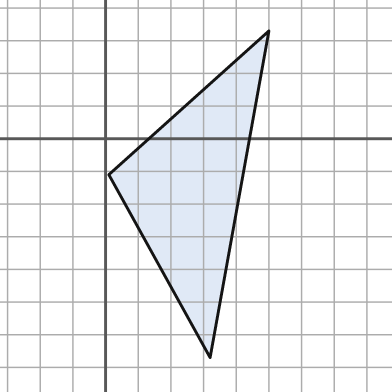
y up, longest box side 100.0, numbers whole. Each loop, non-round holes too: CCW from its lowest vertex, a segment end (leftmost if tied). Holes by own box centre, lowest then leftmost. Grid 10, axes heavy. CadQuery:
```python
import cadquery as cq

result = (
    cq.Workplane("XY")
    .moveTo(32.0, -67.0)
    .lineTo(50.0, 33.0)
    .lineTo(1.0, -11.0)
    .close()
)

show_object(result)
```